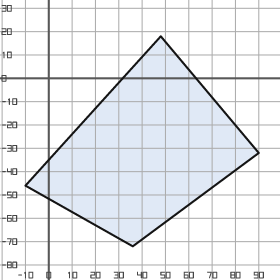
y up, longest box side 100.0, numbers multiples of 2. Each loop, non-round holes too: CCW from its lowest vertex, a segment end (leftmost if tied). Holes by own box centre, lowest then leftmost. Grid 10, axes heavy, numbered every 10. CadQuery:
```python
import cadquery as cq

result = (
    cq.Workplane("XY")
    .moveTo(36.0, -72.0)
    .lineTo(90.0, -32.0)
    .lineTo(48.0, 18.0)
    .lineTo(-10.0, -46.0)
    .close()
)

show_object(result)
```